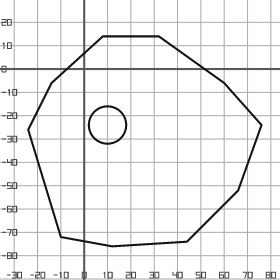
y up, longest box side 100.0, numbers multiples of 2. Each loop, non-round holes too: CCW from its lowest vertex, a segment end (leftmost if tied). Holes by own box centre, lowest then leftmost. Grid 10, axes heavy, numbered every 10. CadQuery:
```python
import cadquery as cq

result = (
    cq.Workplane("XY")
    .moveTo(12.0, -76.0)
    .lineTo(44.0, -74.0)
    .lineTo(66.0, -52.0)
    .lineTo(76.0, -24.0)
    .lineTo(60.0, -6.0)
    .lineTo(32.0, 14.0)
    .lineTo(8.0, 14.0)
    .lineTo(-14.0, -6.0)
    .lineTo(-24.0, -26.0)
    .lineTo(-10.0, -72.0)
    .close()
    .moveTo(10.0, -24.0)
    .circle(8.0)
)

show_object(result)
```